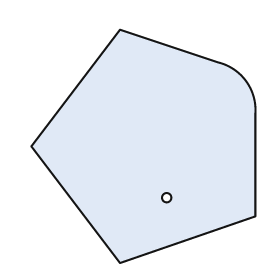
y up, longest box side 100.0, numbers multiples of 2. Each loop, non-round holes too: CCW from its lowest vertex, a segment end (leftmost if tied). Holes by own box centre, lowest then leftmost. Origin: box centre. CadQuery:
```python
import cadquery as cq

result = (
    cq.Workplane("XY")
    .moveTo(-10.0, -50.0)
    .lineTo(48.0, -30.0)
    .lineTo(48.0, 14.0)
    .threePointArc((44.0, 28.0), (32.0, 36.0))
    .lineTo(-10.0, 50.0)
    .lineTo(-48.0, 0.0)
    .close()
    .moveTo(10.0, -22.0)
    .circle(2.0)
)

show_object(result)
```